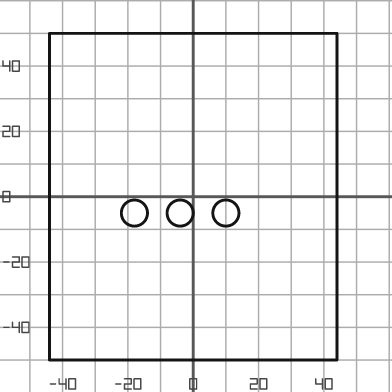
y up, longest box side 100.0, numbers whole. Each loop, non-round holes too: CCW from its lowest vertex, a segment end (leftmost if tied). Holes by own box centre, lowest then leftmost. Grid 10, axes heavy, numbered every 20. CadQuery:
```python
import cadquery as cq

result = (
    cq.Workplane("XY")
    .moveTo(-44.0, -50.0)
    .lineTo(44.0, -50.0)
    .lineTo(44.0, 50.0)
    .lineTo(-44.0, 50.0)
    .close()
    .moveTo(-18.0, -5.0)
    .circle(4.0)
    .moveTo(-4.0, -5.0)
    .circle(4.0)
    .moveTo(10.0, -5.0)
    .circle(4.0)
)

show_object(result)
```